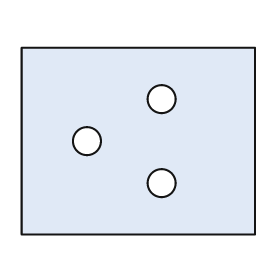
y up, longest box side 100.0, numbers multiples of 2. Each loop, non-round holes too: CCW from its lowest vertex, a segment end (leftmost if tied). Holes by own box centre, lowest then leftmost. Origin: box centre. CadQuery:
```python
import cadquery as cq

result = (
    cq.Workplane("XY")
    .moveTo(-50.0, -40.0)
    .lineTo(50.0, -40.0)
    .lineTo(50.0, 40.0)
    .lineTo(-50.0, 40.0)
    .close()
    .moveTo(10.0, -18.0)
    .circle(6.0)
    .moveTo(-22.0, 0.0)
    .circle(6.0)
    .moveTo(10.0, 18.0)
    .circle(6.0)
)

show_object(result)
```